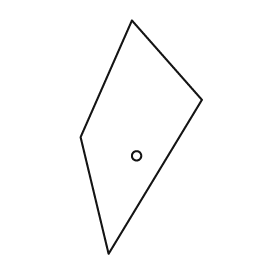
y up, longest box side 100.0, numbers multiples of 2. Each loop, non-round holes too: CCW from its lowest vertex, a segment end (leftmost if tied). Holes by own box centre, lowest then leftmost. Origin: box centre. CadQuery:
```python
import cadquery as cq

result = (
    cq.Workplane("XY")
    .moveTo(-14.0, -50.0)
    .lineTo(26.0, 16.0)
    .lineTo(-4.0, 50.0)
    .lineTo(-26.0, 0.0)
    .close()
    .moveTo(-2.0, -8.0)
    .circle(2.0)
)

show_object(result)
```